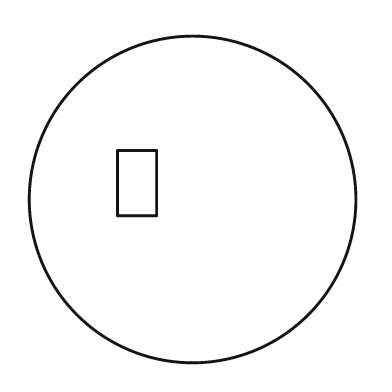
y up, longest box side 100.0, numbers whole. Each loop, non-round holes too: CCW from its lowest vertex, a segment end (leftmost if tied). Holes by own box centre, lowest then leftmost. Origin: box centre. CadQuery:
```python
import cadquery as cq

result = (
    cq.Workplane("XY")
    .moveTo(0.0, 0.0)
    .circle(50.0)
    .moveTo(-23.0, -5.0)
    .lineTo(-11.0, -5.0)
    .lineTo(-11.0, 15.0)
    .lineTo(-23.0, 15.0)
    .close()
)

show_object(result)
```